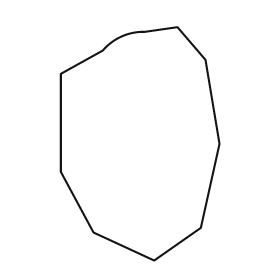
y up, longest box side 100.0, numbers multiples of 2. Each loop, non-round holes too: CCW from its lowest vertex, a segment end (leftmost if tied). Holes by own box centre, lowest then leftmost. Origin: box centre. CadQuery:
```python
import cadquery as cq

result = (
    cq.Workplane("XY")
    .moveTo(6.0, -50.0)
    .lineTo(26.0, -36.0)
    .lineTo(34.0, 0.0)
    .lineTo(28.0, 36.0)
    .lineTo(16.0, 50.0)
    .lineTo(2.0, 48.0)
    .threePointArc((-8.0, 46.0), (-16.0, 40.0))
    .lineTo(-34.0, 30.0)
    .lineTo(-34.0, -12.0)
    .lineTo(-20.0, -38.0)
    .close()
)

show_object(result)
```